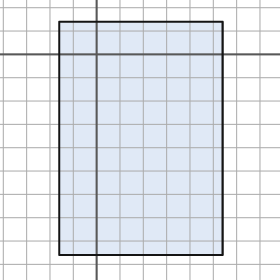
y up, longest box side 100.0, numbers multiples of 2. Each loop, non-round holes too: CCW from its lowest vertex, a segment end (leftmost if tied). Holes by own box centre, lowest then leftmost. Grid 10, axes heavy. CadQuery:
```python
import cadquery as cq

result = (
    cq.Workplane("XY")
    .moveTo(-16.0, -86.0)
    .lineTo(54.0, -86.0)
    .lineTo(54.0, 14.0)
    .lineTo(-16.0, 14.0)
    .close()
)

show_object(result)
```